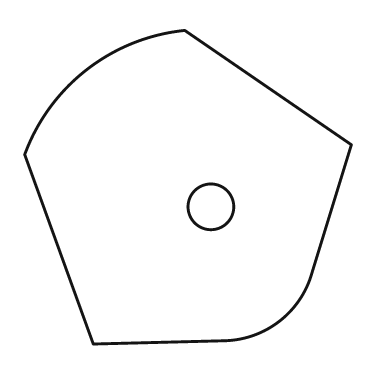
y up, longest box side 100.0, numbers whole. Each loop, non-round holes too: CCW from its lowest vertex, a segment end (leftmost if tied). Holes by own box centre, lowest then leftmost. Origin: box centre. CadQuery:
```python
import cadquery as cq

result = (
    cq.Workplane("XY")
    .moveTo(-29.0, -48.0)
    .lineTo(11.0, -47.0)
    .threePointArc((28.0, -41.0), (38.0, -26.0))
    .lineTo(50.0, 13.0)
    .lineTo(-1.0, 48.0)
    .threePointArc((-31.0, 36.0), (-50.0, 10.0))
    .close()
    .moveTo(7.0, -6.0)
    .circle(7.0)
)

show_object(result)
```